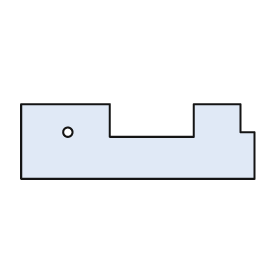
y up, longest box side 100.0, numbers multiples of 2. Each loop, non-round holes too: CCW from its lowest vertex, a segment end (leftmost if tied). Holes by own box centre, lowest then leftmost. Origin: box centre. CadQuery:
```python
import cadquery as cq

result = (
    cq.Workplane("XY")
    .moveTo(-50.0, -16.0)
    .lineTo(50.0, -16.0)
    .lineTo(50.0, 4.0)
    .lineTo(44.0, 4.0)
    .lineTo(44.0, 16.0)
    .lineTo(24.0, 16.0)
    .lineTo(24.0, 2.0)
    .lineTo(-12.0, 2.0)
    .lineTo(-12.0, 16.0)
    .lineTo(-50.0, 16.0)
    .close()
    .moveTo(-30.0, 4.0)
    .circle(2.0)
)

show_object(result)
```